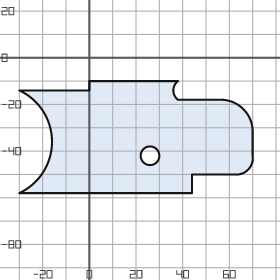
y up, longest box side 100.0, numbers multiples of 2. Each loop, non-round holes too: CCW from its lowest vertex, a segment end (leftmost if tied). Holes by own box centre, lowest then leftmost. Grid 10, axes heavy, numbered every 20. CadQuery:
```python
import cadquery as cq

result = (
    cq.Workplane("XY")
    .moveTo(-30.0, -58.0)
    .lineTo(44.0, -58.0)
    .lineTo(44.0, -50.0)
    .lineTo(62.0, -50.0)
    .threePointArc((68.0, -48.0), (70.0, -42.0))
    .lineTo(70.0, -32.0)
    .threePointArc((66.0, -22.0), (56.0, -18.0))
    .lineTo(38.0, -18.0)
    .threePointArc((36.0, -14.0), (38.0, -10.0))
    .lineTo(0.0, -10.0)
    .lineTo(0.0, -14.0)
    .lineTo(-30.0, -14.0)
    .threePointArc((-16.0, -36.0), (-30.0, -58.0))
    .close()
    .moveTo(26.0, -42.0)
    .circle(4.0)
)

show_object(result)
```